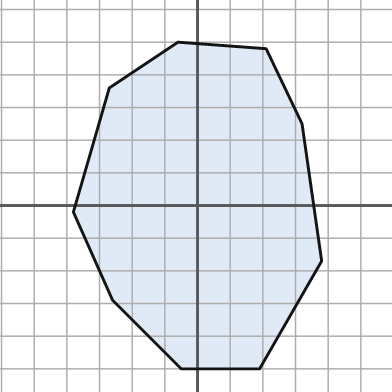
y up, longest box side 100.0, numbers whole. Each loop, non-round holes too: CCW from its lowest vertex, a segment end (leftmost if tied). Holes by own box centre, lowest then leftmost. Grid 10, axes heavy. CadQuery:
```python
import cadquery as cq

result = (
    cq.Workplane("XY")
    .moveTo(-5.0, -50.0)
    .lineTo(19.0, -50.0)
    .lineTo(38.0, -17.0)
    .lineTo(32.0, 25.0)
    .lineTo(21.0, 48.0)
    .lineTo(-6.0, 50.0)
    .lineTo(-27.0, 36.0)
    .lineTo(-38.0, -2.0)
    .lineTo(-26.0, -29.0)
    .close()
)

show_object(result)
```